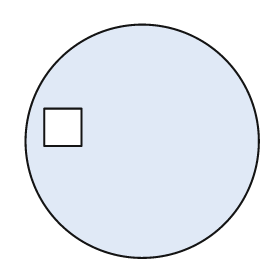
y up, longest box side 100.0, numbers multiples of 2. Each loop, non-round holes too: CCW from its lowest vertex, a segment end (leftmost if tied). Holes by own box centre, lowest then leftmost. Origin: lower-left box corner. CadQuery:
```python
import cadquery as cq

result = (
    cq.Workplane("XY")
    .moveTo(50.0, 50.0)
    .circle(50.0)
    .moveTo(8.0, 48.0)
    .lineTo(24.0, 48.0)
    .lineTo(24.0, 64.0)
    .lineTo(8.0, 64.0)
    .close()
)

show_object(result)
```